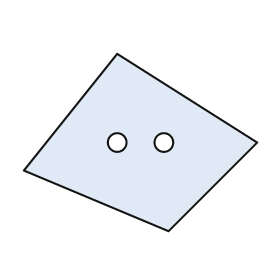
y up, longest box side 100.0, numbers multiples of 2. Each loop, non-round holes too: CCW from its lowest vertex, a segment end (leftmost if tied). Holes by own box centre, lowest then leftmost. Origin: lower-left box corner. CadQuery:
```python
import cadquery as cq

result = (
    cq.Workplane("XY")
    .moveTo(62.0, 0.0)
    .lineTo(100.0, 38.0)
    .lineTo(40.0, 76.0)
    .lineTo(0.0, 26.0)
    .close()
    .moveTo(40.0, 38.0)
    .circle(4.0)
    .moveTo(60.0, 38.0)
    .circle(4.0)
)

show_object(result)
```